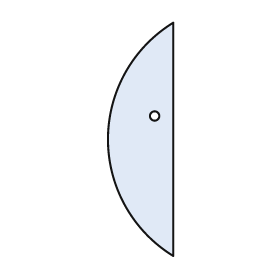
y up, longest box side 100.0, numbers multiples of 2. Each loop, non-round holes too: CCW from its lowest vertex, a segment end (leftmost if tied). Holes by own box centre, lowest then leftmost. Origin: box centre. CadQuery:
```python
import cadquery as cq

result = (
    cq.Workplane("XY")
    .moveTo(14.0, -50.0)
    .lineTo(14.0, 50.0)
    .threePointArc((-14.0, 0.0), (14.0, -50.0))
    .close()
    .moveTo(6.0, 10.0)
    .circle(2.0)
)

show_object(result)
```